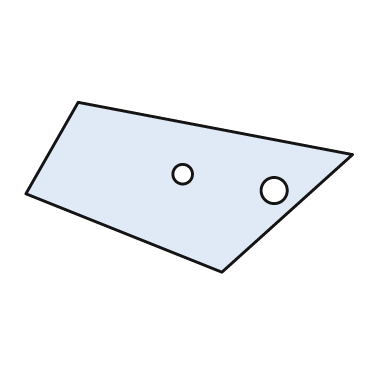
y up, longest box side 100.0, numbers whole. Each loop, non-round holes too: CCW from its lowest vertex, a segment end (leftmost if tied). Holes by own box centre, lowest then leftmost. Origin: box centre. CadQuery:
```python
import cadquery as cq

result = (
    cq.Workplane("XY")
    .moveTo(10.0, -26.0)
    .lineTo(50.0, 10.0)
    .lineTo(-34.0, 26.0)
    .lineTo(-50.0, -2.0)
    .close()
    .moveTo(26.0, -1.0)
    .circle(4.0)
    .moveTo(-2.0, 4.0)
    .circle(3.0)
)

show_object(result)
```